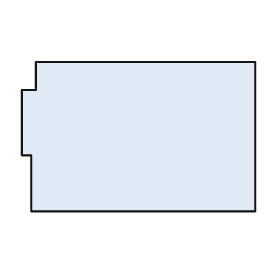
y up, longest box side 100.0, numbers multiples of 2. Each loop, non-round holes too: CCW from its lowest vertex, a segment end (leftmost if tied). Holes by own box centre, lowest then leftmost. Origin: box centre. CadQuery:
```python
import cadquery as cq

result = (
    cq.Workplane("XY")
    .moveTo(-46.0, -32.0)
    .lineTo(50.0, -32.0)
    .lineTo(50.0, 32.0)
    .lineTo(-44.0, 32.0)
    .lineTo(-44.0, 20.0)
    .lineTo(-50.0, 20.0)
    .lineTo(-50.0, -8.0)
    .lineTo(-46.0, -8.0)
    .close()
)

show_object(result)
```